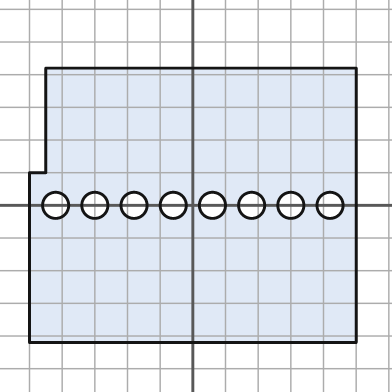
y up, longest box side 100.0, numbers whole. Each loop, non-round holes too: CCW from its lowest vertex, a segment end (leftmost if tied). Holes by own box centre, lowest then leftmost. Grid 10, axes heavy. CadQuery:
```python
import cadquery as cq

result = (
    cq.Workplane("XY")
    .moveTo(-50.0, -42.0)
    .lineTo(50.0, -42.0)
    .lineTo(50.0, 42.0)
    .lineTo(-45.0, 42.0)
    .lineTo(-45.0, 10.0)
    .lineTo(-50.0, 10.0)
    .close()
    .moveTo(-42.0, 0.0)
    .circle(4.0)
    .moveTo(-30.0, 0.0)
    .circle(4.0)
    .moveTo(-18.0, 0.0)
    .circle(4.0)
    .moveTo(-6.0, 0.0)
    .circle(4.0)
    .moveTo(6.0, 0.0)
    .circle(4.0)
    .moveTo(18.0, 0.0)
    .circle(4.0)
    .moveTo(30.0, 0.0)
    .circle(4.0)
    .moveTo(42.0, 0.0)
    .circle(4.0)
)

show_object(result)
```